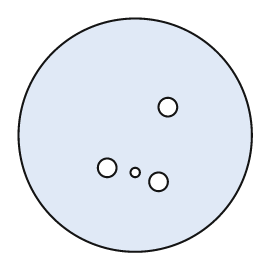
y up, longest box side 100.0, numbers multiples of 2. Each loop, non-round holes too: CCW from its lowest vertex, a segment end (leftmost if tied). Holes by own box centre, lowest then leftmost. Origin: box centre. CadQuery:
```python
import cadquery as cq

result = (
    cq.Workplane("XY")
    .moveTo(0.0, 0.0)
    .circle(50.0)
    .moveTo(10.0, -20.0)
    .circle(4.0)
    .moveTo(0.0, -16.0)
    .circle(2.0)
    .moveTo(-12.0, -14.0)
    .circle(4.0)
    .moveTo(14.0, 12.0)
    .circle(4.0)
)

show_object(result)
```